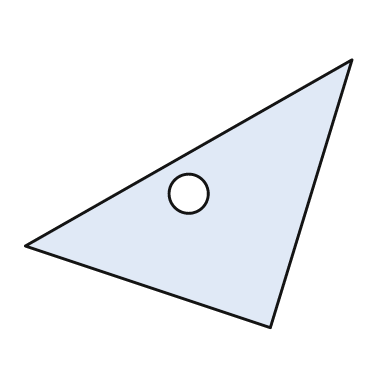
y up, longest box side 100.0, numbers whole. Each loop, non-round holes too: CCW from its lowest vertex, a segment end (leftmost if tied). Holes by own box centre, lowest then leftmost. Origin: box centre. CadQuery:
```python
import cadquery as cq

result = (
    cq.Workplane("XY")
    .moveTo(25.0, -41.0)
    .lineTo(50.0, 41.0)
    .lineTo(-50.0, -16.0)
    .close()
    .moveTo(0.0, 0.0)
    .circle(6.0)
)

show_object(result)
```